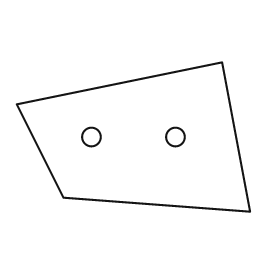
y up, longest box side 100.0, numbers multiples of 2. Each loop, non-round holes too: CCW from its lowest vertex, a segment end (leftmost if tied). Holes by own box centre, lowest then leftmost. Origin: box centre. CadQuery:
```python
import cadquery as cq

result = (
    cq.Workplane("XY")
    .moveTo(50.0, -32.0)
    .lineTo(38.0, 32.0)
    .lineTo(-50.0, 14.0)
    .lineTo(-30.0, -26.0)
    .close()
    .moveTo(-18.0, 0.0)
    .circle(4.0)
    .moveTo(18.0, 0.0)
    .circle(4.0)
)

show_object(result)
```